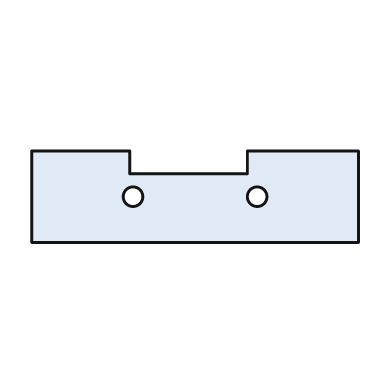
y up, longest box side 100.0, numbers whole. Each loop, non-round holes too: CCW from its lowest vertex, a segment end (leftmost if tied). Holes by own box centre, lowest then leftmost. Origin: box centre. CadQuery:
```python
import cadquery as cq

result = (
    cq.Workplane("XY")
    .moveTo(-50.0, -14.0)
    .lineTo(50.0, -14.0)
    .lineTo(50.0, 14.0)
    .lineTo(16.0, 14.0)
    .lineTo(16.0, 7.0)
    .lineTo(-20.0, 7.0)
    .lineTo(-20.0, 14.0)
    .lineTo(-50.0, 14.0)
    .close()
    .moveTo(-19.0, 0.0)
    .circle(3.0)
    .moveTo(19.0, 0.0)
    .circle(3.0)
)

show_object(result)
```